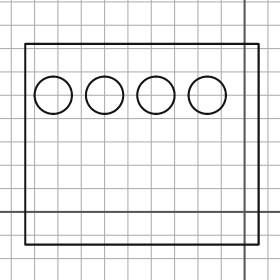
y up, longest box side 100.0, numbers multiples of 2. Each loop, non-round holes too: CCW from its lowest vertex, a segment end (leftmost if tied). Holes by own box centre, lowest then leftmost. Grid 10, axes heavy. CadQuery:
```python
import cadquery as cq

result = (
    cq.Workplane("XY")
    .moveTo(-94.0, -14.0)
    .lineTo(6.0, -14.0)
    .lineTo(6.0, 72.0)
    .lineTo(-94.0, 72.0)
    .close()
    .moveTo(-82.0, 50.0)
    .circle(8.0)
    .moveTo(-60.0, 50.0)
    .circle(8.0)
    .moveTo(-38.0, 50.0)
    .circle(8.0)
    .moveTo(-16.0, 50.0)
    .circle(8.0)
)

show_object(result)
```